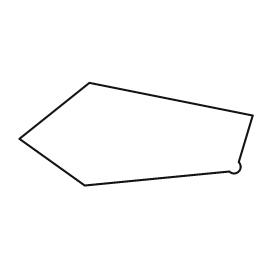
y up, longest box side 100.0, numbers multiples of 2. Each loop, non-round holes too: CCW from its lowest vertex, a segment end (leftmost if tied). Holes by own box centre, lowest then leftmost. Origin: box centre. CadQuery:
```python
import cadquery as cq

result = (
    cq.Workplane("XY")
    .moveTo(-22.0, -22.0)
    .lineTo(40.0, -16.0)
    .threePointArc((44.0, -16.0), (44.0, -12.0))
    .lineTo(50.0, 8.0)
    .lineTo(-20.0, 22.0)
    .lineTo(-50.0, -2.0)
    .close()
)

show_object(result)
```